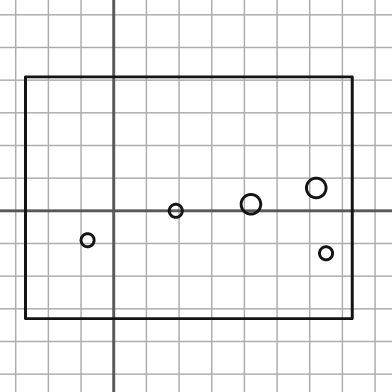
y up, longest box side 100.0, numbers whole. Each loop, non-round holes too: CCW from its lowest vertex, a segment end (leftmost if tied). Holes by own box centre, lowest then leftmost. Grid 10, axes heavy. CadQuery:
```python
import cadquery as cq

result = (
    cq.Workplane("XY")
    .moveTo(-27.0, -33.0)
    .lineTo(73.0, -33.0)
    .lineTo(73.0, 41.0)
    .lineTo(-27.0, 41.0)
    .close()
    .moveTo(65.0, -13.0)
    .circle(2.0)
    .moveTo(-8.0, -9.0)
    .circle(2.0)
    .moveTo(19.0, 0.0)
    .circle(2.0)
    .moveTo(42.0, 2.0)
    .circle(3.0)
    .moveTo(62.0, 7.0)
    .circle(3.0)
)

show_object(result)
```